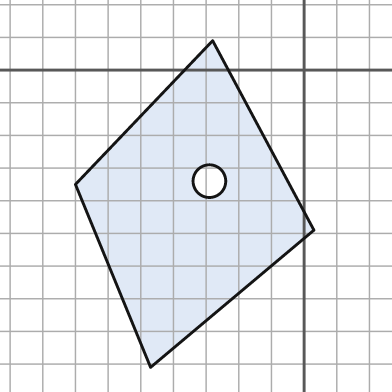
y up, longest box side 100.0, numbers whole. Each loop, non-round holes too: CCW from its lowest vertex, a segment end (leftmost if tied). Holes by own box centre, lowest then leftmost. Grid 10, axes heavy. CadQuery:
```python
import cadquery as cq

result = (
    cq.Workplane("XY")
    .moveTo(-47.0, -91.0)
    .lineTo(3.0, -49.0)
    .lineTo(-28.0, 9.0)
    .lineTo(-70.0, -35.0)
    .close()
    .moveTo(-29.0, -34.0)
    .circle(5.0)
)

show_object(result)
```